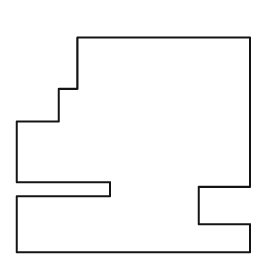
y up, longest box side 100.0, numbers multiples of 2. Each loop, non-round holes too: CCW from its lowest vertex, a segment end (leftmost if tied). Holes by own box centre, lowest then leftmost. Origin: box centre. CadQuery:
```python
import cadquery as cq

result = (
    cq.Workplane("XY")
    .moveTo(-50.0, -46.0)
    .lineTo(50.0, -46.0)
    .lineTo(50.0, -34.0)
    .lineTo(28.0, -34.0)
    .lineTo(28.0, -18.0)
    .lineTo(50.0, -18.0)
    .lineTo(50.0, 46.0)
    .lineTo(-24.0, 46.0)
    .lineTo(-24.0, 24.0)
    .lineTo(-32.0, 24.0)
    .lineTo(-32.0, 10.0)
    .lineTo(-50.0, 10.0)
    .lineTo(-50.0, -16.0)
    .lineTo(-10.0, -16.0)
    .lineTo(-10.0, -22.0)
    .lineTo(-50.0, -22.0)
    .close()
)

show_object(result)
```